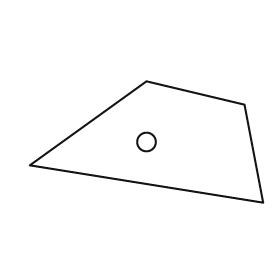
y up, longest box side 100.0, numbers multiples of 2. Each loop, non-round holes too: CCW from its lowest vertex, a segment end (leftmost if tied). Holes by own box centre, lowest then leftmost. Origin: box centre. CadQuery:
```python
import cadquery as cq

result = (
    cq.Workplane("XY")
    .moveTo(50.0, -26.0)
    .lineTo(42.0, 16.0)
    .lineTo(0.0, 26.0)
    .lineTo(-50.0, -10.0)
    .close()
    .moveTo(0.0, 0.0)
    .circle(4.0)
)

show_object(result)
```